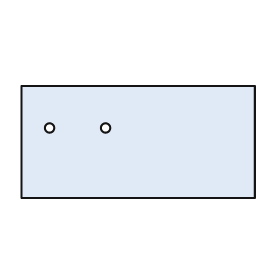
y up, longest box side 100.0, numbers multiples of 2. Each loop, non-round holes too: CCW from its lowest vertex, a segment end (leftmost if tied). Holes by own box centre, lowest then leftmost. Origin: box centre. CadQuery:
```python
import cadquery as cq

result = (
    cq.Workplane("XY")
    .moveTo(-50.0, -24.0)
    .lineTo(50.0, -24.0)
    .lineTo(50.0, 24.0)
    .lineTo(-50.0, 24.0)
    .close()
    .moveTo(-38.0, 6.0)
    .circle(2.0)
    .moveTo(-14.0, 6.0)
    .circle(2.0)
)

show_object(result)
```